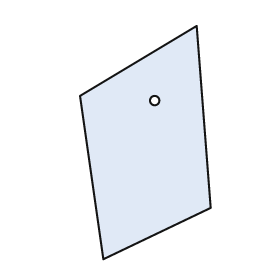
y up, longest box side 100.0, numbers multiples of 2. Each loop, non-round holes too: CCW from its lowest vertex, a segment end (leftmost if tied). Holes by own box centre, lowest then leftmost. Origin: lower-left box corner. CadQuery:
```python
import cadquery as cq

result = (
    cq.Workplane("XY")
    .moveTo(10.0, 0.0)
    .lineTo(56.0, 22.0)
    .lineTo(50.0, 100.0)
    .lineTo(0.0, 70.0)
    .close()
    .moveTo(32.0, 68.0)
    .circle(2.0)
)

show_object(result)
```